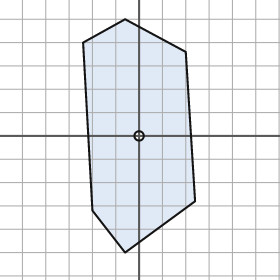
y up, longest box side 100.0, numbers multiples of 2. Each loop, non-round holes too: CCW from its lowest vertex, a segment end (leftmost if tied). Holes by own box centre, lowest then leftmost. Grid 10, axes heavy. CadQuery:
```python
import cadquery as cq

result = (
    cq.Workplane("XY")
    .moveTo(-6.0, -50.0)
    .lineTo(24.0, -28.0)
    .lineTo(20.0, 36.0)
    .lineTo(-6.0, 50.0)
    .lineTo(-24.0, 40.0)
    .lineTo(-20.0, -32.0)
    .close()
    .moveTo(0.0, 0.0)
    .circle(2.0)
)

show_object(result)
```